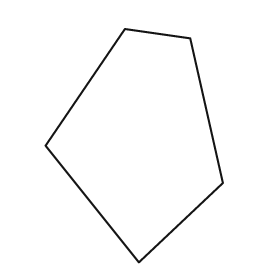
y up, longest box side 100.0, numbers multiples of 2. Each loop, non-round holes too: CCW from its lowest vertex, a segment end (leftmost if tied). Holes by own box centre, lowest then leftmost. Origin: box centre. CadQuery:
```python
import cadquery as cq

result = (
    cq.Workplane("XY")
    .moveTo(2.0, -50.0)
    .lineTo(38.0, -16.0)
    .lineTo(24.0, 46.0)
    .lineTo(-4.0, 50.0)
    .lineTo(-38.0, 0.0)
    .close()
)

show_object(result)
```